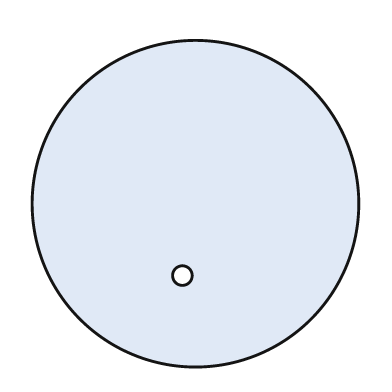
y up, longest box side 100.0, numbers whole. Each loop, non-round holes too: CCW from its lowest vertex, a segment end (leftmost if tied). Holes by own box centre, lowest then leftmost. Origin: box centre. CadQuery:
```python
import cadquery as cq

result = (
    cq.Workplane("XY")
    .moveTo(0.0, 0.0)
    .circle(50.0)
    .moveTo(-4.0, -22.0)
    .circle(3.0)
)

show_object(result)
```